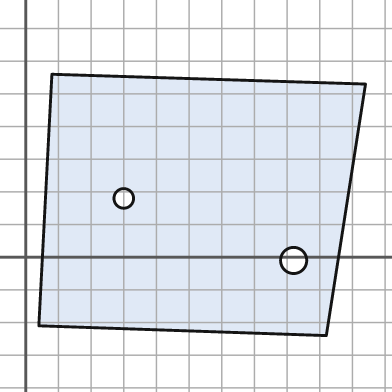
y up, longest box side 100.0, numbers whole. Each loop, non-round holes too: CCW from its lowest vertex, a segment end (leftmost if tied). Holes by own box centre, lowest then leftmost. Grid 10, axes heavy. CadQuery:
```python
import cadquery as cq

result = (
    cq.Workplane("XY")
    .moveTo(92.0, -24.0)
    .lineTo(104.0, 53.0)
    .lineTo(8.0, 56.0)
    .lineTo(4.0, -21.0)
    .close()
    .moveTo(82.0, -1.0)
    .circle(4.0)
    .moveTo(30.0, 18.0)
    .circle(3.0)
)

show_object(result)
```